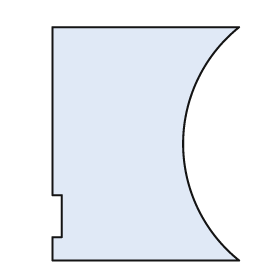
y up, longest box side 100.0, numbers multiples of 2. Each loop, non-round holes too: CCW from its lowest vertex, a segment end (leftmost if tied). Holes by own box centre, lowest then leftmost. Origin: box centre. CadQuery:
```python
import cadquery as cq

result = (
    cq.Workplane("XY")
    .moveTo(-40.0, -50.0)
    .lineTo(40.0, -50.0)
    .threePointArc((16.0, 0.0), (40.0, 50.0))
    .lineTo(-40.0, 50.0)
    .lineTo(-40.0, -22.0)
    .lineTo(-36.0, -22.0)
    .lineTo(-36.0, -40.0)
    .lineTo(-40.0, -40.0)
    .close()
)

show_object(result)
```